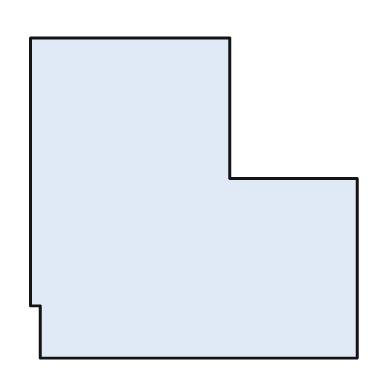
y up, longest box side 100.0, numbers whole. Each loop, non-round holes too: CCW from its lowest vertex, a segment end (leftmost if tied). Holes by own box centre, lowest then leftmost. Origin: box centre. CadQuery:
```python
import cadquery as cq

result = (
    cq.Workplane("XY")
    .moveTo(-47.0, -49.0)
    .lineTo(50.0, -49.0)
    .lineTo(50.0, 6.0)
    .lineTo(11.0, 6.0)
    .lineTo(11.0, 49.0)
    .lineTo(-50.0, 49.0)
    .lineTo(-50.0, -33.0)
    .lineTo(-47.0, -33.0)
    .close()
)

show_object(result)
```